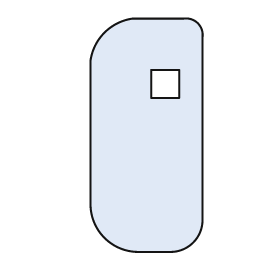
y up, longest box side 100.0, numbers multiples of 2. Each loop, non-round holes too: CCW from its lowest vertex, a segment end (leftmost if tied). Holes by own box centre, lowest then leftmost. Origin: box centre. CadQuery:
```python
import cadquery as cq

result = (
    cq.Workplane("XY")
    .moveTo(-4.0, -50.0)
    .lineTo(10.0, -50.0)
    .threePointArc((20.0, -46.0), (24.0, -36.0))
    .lineTo(24.0, 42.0)
    .threePointArc((22.0, 48.0), (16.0, 50.0))
    .lineTo(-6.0, 50.0)
    .threePointArc((-18.0, 44.0), (-24.0, 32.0))
    .lineTo(-24.0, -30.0)
    .threePointArc((-18.0, -44.0), (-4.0, -50.0))
    .close()
    .moveTo(2.0, 16.0)
    .lineTo(14.0, 16.0)
    .lineTo(14.0, 28.0)
    .lineTo(2.0, 28.0)
    .close()
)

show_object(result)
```